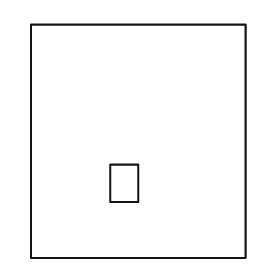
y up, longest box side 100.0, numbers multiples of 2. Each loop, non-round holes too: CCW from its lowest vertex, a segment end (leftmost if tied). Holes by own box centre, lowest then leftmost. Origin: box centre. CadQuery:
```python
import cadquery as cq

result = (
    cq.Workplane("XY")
    .moveTo(-46.0, -50.0)
    .lineTo(46.0, -50.0)
    .lineTo(46.0, 50.0)
    .lineTo(-46.0, 50.0)
    .close()
    .moveTo(-12.0, -26.0)
    .lineTo(0.0, -26.0)
    .lineTo(0.0, -10.0)
    .lineTo(-12.0, -10.0)
    .close()
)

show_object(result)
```